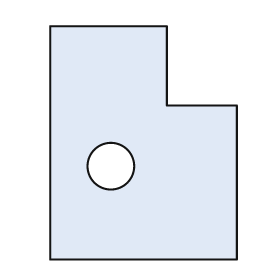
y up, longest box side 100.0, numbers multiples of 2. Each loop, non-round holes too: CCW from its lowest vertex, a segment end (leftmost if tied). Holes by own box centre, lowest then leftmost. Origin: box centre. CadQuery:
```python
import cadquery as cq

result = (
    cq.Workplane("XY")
    .moveTo(-40.0, -50.0)
    .lineTo(40.0, -50.0)
    .lineTo(40.0, 16.0)
    .lineTo(10.0, 16.0)
    .lineTo(10.0, 50.0)
    .lineTo(-40.0, 50.0)
    .close()
    .moveTo(-14.0, -10.0)
    .circle(10.0)
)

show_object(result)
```